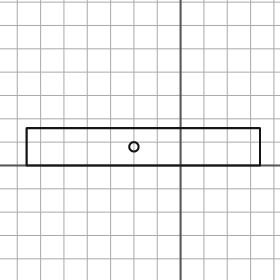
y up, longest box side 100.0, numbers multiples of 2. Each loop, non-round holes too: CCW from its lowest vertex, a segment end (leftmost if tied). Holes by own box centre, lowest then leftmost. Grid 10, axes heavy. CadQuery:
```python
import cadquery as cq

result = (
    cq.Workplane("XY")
    .moveTo(-66.0, 0.0)
    .lineTo(34.0, 0.0)
    .lineTo(34.0, 16.0)
    .lineTo(-66.0, 16.0)
    .close()
    .moveTo(-20.0, 8.0)
    .circle(2.0)
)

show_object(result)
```